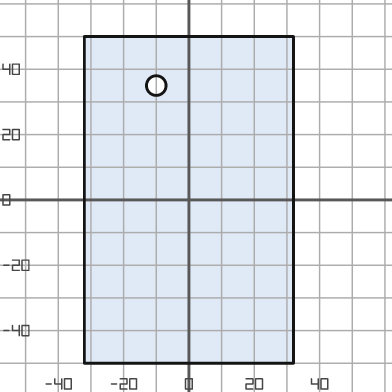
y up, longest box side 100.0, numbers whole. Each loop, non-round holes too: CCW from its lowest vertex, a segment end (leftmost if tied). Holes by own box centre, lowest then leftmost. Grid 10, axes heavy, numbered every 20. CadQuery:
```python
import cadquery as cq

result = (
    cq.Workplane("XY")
    .moveTo(-32.0, -50.0)
    .lineTo(32.0, -50.0)
    .lineTo(32.0, 50.0)
    .lineTo(-32.0, 50.0)
    .close()
    .moveTo(-10.0, 35.0)
    .circle(3.0)
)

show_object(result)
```